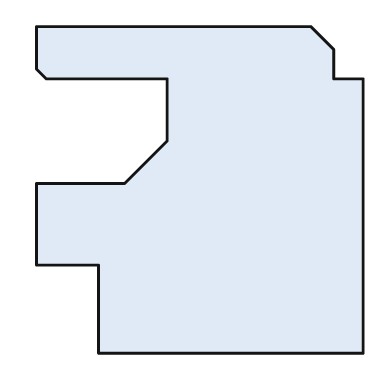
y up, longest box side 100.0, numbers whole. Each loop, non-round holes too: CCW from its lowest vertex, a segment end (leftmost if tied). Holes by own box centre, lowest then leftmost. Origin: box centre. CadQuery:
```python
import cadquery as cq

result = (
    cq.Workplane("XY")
    .moveTo(-31.0, -50.0)
    .lineTo(50.0, -50.0)
    .lineTo(50.0, 34.0)
    .lineTo(41.0, 34.0)
    .lineTo(41.0, 43.0)
    .lineTo(34.0, 50.0)
    .lineTo(-50.0, 50.0)
    .lineTo(-50.0, 37.0)
    .lineTo(-47.0, 34.0)
    .lineTo(-10.0, 34.0)
    .lineTo(-10.0, 15.0)
    .lineTo(-23.0, 2.0)
    .lineTo(-50.0, 2.0)
    .lineTo(-50.0, -23.0)
    .lineTo(-31.0, -23.0)
    .close()
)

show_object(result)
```